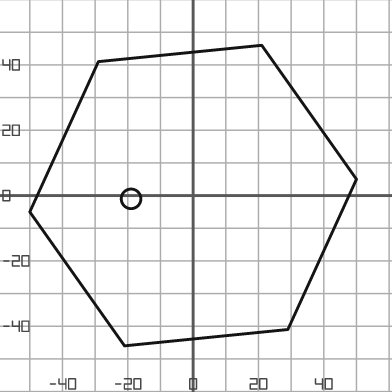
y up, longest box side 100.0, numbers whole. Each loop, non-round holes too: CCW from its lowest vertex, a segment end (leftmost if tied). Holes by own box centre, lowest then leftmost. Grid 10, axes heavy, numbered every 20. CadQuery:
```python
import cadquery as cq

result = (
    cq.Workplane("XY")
    .moveTo(-21.0, -46.0)
    .lineTo(29.0, -41.0)
    .lineTo(50.0, 5.0)
    .lineTo(21.0, 46.0)
    .lineTo(-29.0, 41.0)
    .lineTo(-50.0, -5.0)
    .close()
    .moveTo(-19.0, -1.0)
    .circle(3.0)
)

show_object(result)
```